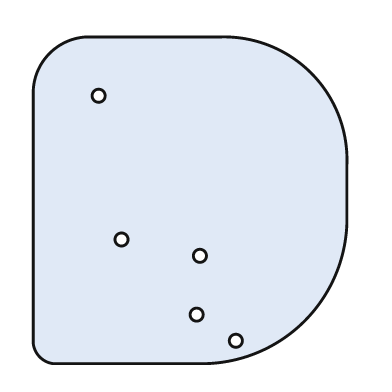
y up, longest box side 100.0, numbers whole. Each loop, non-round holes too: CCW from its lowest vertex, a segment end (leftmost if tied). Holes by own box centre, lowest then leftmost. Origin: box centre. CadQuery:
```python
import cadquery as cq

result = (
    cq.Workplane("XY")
    .moveTo(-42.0, -50.0)
    .lineTo(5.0, -50.0)
    .threePointArc((35.0, -37.0), (48.0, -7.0))
    .lineTo(48.0, 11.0)
    .threePointArc((37.0, 39.0), (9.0, 50.0))
    .lineTo(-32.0, 50.0)
    .threePointArc((-43.0, 45.0), (-48.0, 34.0))
    .lineTo(-48.0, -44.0)
    .threePointArc((-46.0, -48.0), (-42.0, -50.0))
    .close()
    .moveTo(14.0, -43.0)
    .circle(2.0)
    .moveTo(2.0, -35.0)
    .circle(2.0)
    .moveTo(3.0, -17.0)
    .circle(2.0)
    .moveTo(-21.0, -12.0)
    .circle(2.0)
    .moveTo(-28.0, 32.0)
    .circle(2.0)
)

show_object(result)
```